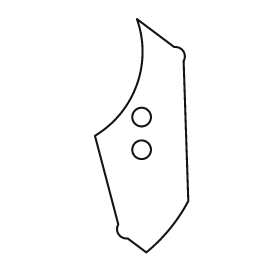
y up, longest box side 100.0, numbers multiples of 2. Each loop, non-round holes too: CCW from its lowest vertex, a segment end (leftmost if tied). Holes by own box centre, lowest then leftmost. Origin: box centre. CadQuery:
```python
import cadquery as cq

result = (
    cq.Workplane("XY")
    .moveTo(2.0, -50.0)
    .threePointArc((12.0, -40.0), (20.0, -28.0))
    .lineTo(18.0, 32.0)
    .threePointArc((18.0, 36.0), (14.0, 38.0))
    .lineTo(-2.0, 50.0)
    .threePointArc((-2.0, 22.0), (-20.0, 0.0))
    .lineTo(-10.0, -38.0)
    .threePointArc((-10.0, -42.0), (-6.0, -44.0))
    .close()
    .moveTo(0.0, -6.0)
    .circle(4.0)
    .moveTo(0.0, 8.0)
    .circle(4.0)
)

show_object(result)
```